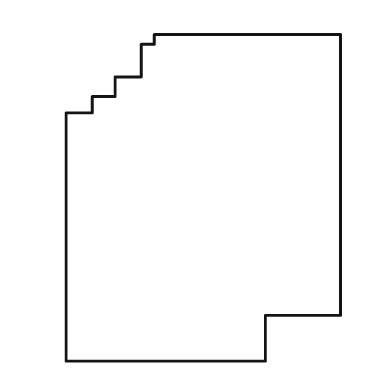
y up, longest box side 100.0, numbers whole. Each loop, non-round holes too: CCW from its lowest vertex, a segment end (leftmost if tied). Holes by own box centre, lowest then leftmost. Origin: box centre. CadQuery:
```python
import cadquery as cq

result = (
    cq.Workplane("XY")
    .moveTo(-42.0, -50.0)
    .lineTo(19.0, -50.0)
    .lineTo(19.0, -36.0)
    .lineTo(42.0, -36.0)
    .lineTo(42.0, 50.0)
    .lineTo(-15.0, 50.0)
    .lineTo(-15.0, 47.0)
    .lineTo(-19.0, 47.0)
    .lineTo(-19.0, 37.0)
    .lineTo(-27.0, 37.0)
    .lineTo(-27.0, 31.0)
    .lineTo(-34.0, 31.0)
    .lineTo(-34.0, 26.0)
    .lineTo(-42.0, 26.0)
    .close()
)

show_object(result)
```